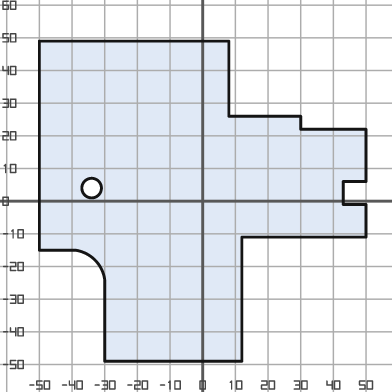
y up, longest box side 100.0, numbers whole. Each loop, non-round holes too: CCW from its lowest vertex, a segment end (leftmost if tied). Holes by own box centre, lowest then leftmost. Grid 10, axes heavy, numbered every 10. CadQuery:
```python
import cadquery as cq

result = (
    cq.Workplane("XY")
    .moveTo(-30.0, -49.0)
    .lineTo(12.0, -49.0)
    .lineTo(12.0, -11.0)
    .lineTo(50.0, -11.0)
    .lineTo(50.0, -1.0)
    .lineTo(43.0, -1.0)
    .lineTo(43.0, 6.0)
    .lineTo(50.0, 6.0)
    .lineTo(50.0, 22.0)
    .lineTo(30.0, 22.0)
    .lineTo(30.0, 26.0)
    .lineTo(8.0, 26.0)
    .lineTo(8.0, 49.0)
    .lineTo(-50.0, 49.0)
    .lineTo(-50.0, -15.0)
    .lineTo(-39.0, -15.0)
    .threePointArc((-33.0, -18.0), (-30.0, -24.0))
    .close()
    .moveTo(-34.0, 4.0)
    .circle(3.0)
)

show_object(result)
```